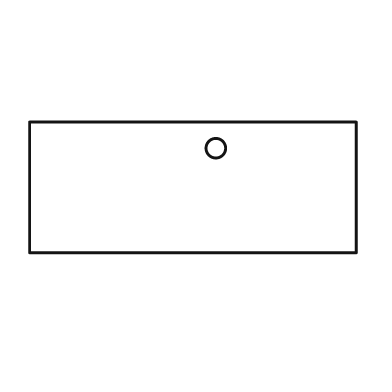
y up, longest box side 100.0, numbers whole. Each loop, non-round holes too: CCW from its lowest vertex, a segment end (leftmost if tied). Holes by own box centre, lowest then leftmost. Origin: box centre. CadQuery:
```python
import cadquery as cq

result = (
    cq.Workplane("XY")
    .moveTo(-50.0, -20.0)
    .lineTo(50.0, -20.0)
    .lineTo(50.0, 20.0)
    .lineTo(-50.0, 20.0)
    .close()
    .moveTo(7.0, 12.0)
    .circle(3.0)
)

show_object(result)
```